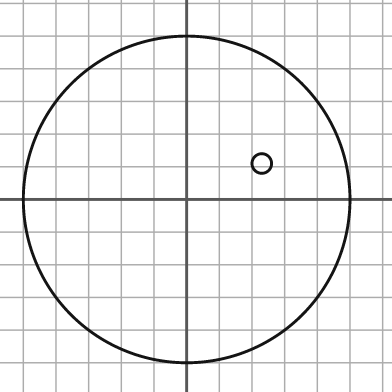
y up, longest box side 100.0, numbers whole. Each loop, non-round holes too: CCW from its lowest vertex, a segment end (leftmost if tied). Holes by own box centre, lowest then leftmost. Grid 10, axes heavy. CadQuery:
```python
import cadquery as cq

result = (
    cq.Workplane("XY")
    .moveTo(0.0, 0.0)
    .circle(50.0)
    .moveTo(23.0, 11.0)
    .circle(3.0)
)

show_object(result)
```